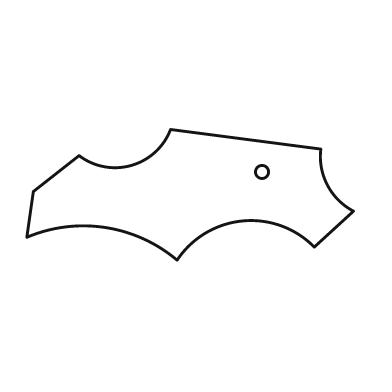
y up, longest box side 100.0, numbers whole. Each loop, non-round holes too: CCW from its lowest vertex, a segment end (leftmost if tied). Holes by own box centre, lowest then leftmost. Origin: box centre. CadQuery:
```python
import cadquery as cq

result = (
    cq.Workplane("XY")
    .moveTo(-4.0, -20.0)
    .threePointArc((16.0, -8.0), (38.0, -16.0))
    .lineTo(50.0, -5.0)
    .threePointArc((42.0, 3.0), (40.0, 14.0))
    .lineTo(-6.0, 20.0)
    .threePointArc((-18.0, 9.0), (-34.0, 12.0))
    .lineTo(-48.0, 1.0)
    .lineTo(-50.0, -13.0)
    .threePointArc((-26.0, -10.0), (-4.0, -20.0))
    .close()
    .moveTo(22.0, 7.0)
    .circle(2.0)
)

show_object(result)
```